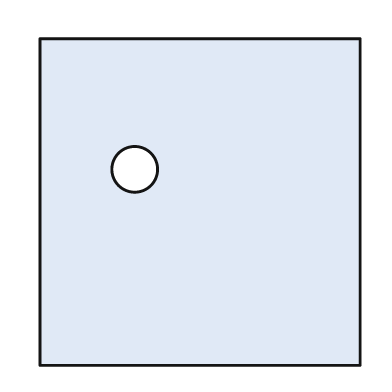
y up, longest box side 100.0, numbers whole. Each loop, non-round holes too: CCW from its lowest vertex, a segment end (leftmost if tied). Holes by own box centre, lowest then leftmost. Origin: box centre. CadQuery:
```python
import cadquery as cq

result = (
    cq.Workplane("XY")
    .moveTo(-49.0, -50.0)
    .lineTo(49.0, -50.0)
    .lineTo(49.0, 50.0)
    .lineTo(-49.0, 50.0)
    .close()
    .moveTo(-20.0, 10.0)
    .circle(7.0)
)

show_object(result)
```